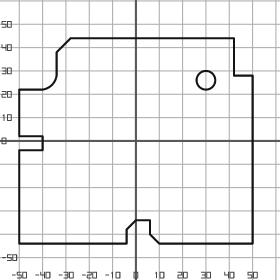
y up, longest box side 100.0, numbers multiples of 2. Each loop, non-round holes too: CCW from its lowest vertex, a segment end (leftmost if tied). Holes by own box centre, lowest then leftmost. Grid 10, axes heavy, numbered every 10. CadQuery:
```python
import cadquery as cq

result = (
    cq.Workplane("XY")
    .moveTo(-50.0, -44.0)
    .lineTo(-4.0, -44.0)
    .lineTo(-4.0, -38.0)
    .lineTo(0.0, -34.0)
    .lineTo(6.0, -34.0)
    .lineTo(6.0, -40.0)
    .lineTo(10.0, -44.0)
    .lineTo(50.0, -44.0)
    .lineTo(50.0, 28.0)
    .lineTo(42.0, 28.0)
    .lineTo(42.0, 44.0)
    .lineTo(-28.0, 44.0)
    .lineTo(-34.0, 38.0)
    .lineTo(-34.0, 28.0)
    .threePointArc((-36.0, 24.0), (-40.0, 22.0))
    .lineTo(-50.0, 22.0)
    .lineTo(-50.0, 2.0)
    .lineTo(-40.0, 2.0)
    .lineTo(-40.0, -4.0)
    .lineTo(-50.0, -4.0)
    .close()
    .moveTo(30.0, 26.0)
    .circle(4.0)
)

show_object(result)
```